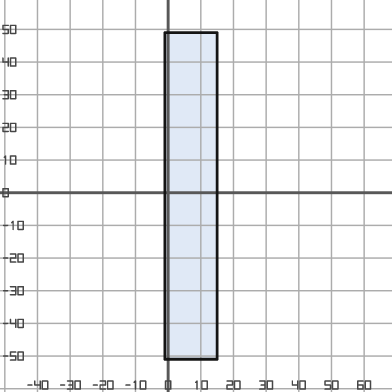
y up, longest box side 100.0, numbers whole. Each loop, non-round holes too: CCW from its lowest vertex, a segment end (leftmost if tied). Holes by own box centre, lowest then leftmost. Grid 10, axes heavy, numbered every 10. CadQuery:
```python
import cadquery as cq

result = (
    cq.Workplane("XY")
    .moveTo(-1.0, -51.0)
    .lineTo(15.0, -51.0)
    .lineTo(15.0, 49.0)
    .lineTo(-1.0, 49.0)
    .close()
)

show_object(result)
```